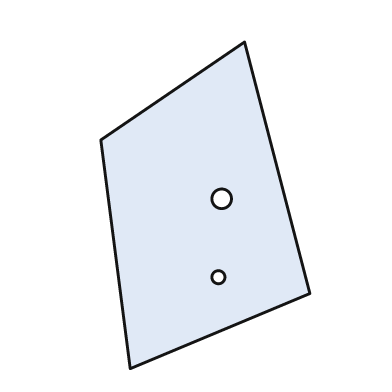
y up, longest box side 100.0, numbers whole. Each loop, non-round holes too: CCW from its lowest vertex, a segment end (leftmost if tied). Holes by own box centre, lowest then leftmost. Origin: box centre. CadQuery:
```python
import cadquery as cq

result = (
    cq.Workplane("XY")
    .moveTo(-23.0, -50.0)
    .lineTo(32.0, -27.0)
    .lineTo(12.0, 50.0)
    .lineTo(-32.0, 20.0)
    .close()
    .moveTo(4.0, -22.0)
    .circle(2.0)
    .moveTo(5.0, 2.0)
    .circle(3.0)
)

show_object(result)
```